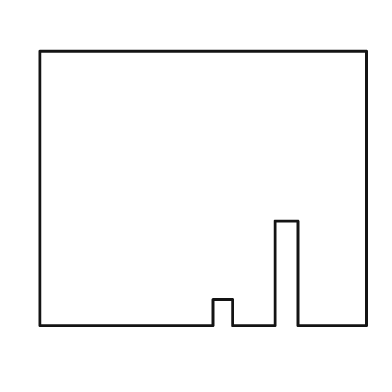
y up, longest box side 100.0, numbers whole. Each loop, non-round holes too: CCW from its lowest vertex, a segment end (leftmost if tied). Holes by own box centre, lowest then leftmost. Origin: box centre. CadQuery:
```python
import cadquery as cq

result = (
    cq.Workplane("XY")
    .moveTo(-50.0, -42.0)
    .lineTo(3.0, -42.0)
    .lineTo(3.0, -34.0)
    .lineTo(9.0, -34.0)
    .lineTo(9.0, -42.0)
    .lineTo(22.0, -42.0)
    .lineTo(22.0, -10.0)
    .lineTo(29.0, -10.0)
    .lineTo(29.0, -42.0)
    .lineTo(50.0, -42.0)
    .lineTo(50.0, 42.0)
    .lineTo(-50.0, 42.0)
    .close()
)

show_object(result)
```